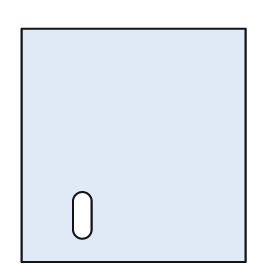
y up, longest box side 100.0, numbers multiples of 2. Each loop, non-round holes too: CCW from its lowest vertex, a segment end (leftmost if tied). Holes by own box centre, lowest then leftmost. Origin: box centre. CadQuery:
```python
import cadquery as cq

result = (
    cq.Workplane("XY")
    .moveTo(-48.0, -50.0)
    .lineTo(48.0, -50.0)
    .lineTo(48.0, 50.0)
    .lineTo(-48.0, 50.0)
    .close()
    .moveTo(-26.0, -36.0)
    .threePointArc((-22.0, -40.0), (-18.0, -36.0))
    .lineTo(-18.0, -24.0)
    .threePointArc((-22.0, -20.0), (-26.0, -24.0))
    .close()
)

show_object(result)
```